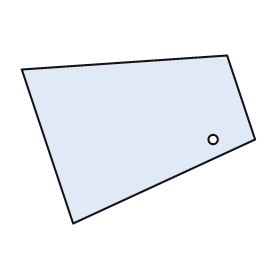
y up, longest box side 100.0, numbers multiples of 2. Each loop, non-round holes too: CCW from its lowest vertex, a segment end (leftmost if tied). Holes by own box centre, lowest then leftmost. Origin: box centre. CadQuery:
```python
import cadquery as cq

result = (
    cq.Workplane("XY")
    .moveTo(-28.0, -36.0)
    .lineTo(50.0, 0.0)
    .lineTo(38.0, 36.0)
    .lineTo(-50.0, 30.0)
    .close()
    .moveTo(32.0, 0.0)
    .circle(2.0)
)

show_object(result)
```